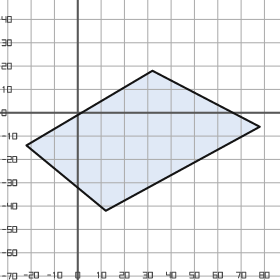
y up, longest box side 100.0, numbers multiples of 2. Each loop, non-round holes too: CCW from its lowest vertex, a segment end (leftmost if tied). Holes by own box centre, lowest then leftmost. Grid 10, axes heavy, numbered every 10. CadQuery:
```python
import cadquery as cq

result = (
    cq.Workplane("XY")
    .moveTo(12.0, -42.0)
    .lineTo(78.0, -6.0)
    .lineTo(32.0, 18.0)
    .lineTo(-22.0, -14.0)
    .close()
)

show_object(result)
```